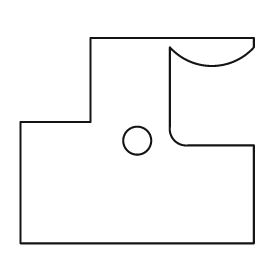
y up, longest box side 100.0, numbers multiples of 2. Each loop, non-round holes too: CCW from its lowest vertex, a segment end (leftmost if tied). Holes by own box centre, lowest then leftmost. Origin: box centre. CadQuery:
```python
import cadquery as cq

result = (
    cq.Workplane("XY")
    .moveTo(-50.0, -44.0)
    .lineTo(50.0, -44.0)
    .lineTo(50.0, -2.0)
    .lineTo(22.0, -2.0)
    .threePointArc((16.0, 0.0), (14.0, 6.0))
    .lineTo(14.0, 40.0)
    .threePointArc((32.0, 32.0), (50.0, 40.0))
    .lineTo(50.0, 44.0)
    .lineTo(-20.0, 44.0)
    .lineTo(-20.0, 8.0)
    .lineTo(-50.0, 8.0)
    .close()
    .moveTo(0.0, 0.0)
    .circle(6.0)
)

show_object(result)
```